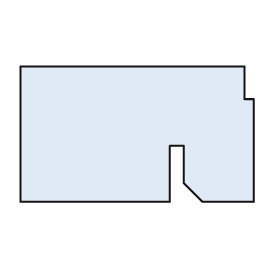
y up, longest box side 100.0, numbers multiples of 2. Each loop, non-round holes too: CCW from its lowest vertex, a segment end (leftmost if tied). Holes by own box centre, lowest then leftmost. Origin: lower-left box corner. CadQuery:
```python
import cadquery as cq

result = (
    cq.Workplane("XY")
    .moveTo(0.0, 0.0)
    .lineTo(64.0, 0.0)
    .lineTo(64.0, 24.0)
    .lineTo(70.0, 24.0)
    .lineTo(70.0, 8.0)
    .lineTo(78.0, 0.0)
    .lineTo(100.0, 0.0)
    .lineTo(100.0, 44.0)
    .lineTo(96.0, 44.0)
    .lineTo(96.0, 58.0)
    .lineTo(0.0, 58.0)
    .close()
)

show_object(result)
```